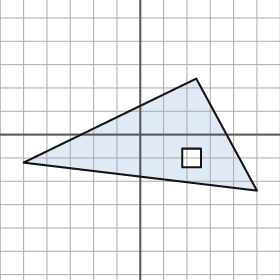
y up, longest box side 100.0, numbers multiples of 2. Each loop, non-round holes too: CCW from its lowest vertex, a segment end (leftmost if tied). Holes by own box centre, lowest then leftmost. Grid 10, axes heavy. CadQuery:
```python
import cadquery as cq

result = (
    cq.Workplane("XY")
    .moveTo(50.0, -24.0)
    .lineTo(24.0, 24.0)
    .lineTo(-50.0, -12.0)
    .close()
    .moveTo(18.0, -14.0)
    .lineTo(26.0, -14.0)
    .lineTo(26.0, -6.0)
    .lineTo(18.0, -6.0)
    .close()
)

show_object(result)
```